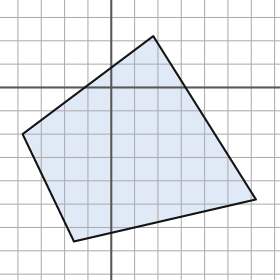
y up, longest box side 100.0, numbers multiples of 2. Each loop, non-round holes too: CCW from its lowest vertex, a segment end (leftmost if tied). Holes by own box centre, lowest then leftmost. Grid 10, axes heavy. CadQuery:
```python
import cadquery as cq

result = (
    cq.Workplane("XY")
    .moveTo(-16.0, -66.0)
    .lineTo(62.0, -48.0)
    .lineTo(18.0, 22.0)
    .lineTo(-38.0, -20.0)
    .close()
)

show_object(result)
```